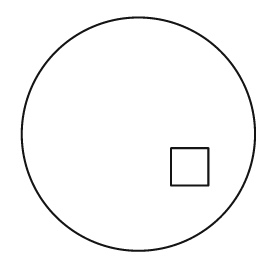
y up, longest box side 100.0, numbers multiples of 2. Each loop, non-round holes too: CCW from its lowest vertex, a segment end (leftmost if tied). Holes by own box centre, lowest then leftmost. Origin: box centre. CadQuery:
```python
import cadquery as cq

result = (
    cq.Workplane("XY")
    .moveTo(0.0, 0.0)
    .circle(50.0)
    .moveTo(14.0, -22.0)
    .lineTo(30.0, -22.0)
    .lineTo(30.0, -6.0)
    .lineTo(14.0, -6.0)
    .close()
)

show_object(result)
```